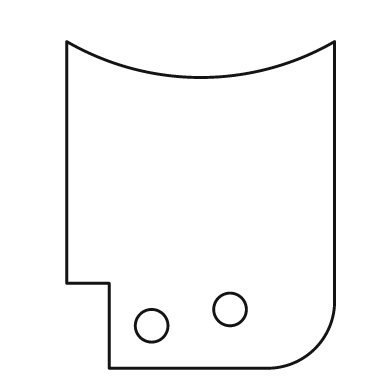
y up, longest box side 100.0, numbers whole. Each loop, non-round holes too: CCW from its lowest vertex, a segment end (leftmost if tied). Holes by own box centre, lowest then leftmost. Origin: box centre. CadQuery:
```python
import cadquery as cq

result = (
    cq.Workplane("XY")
    .moveTo(-28.0, -50.0)
    .lineTo(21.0, -50.0)
    .threePointArc((35.0, -44.0), (41.0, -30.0))
    .lineTo(41.0, 50.0)
    .threePointArc((0.0, 39.0), (-41.0, 50.0))
    .lineTo(-41.0, -24.0)
    .lineTo(-28.0, -24.0)
    .close()
    .moveTo(-15.0, -37.0)
    .circle(5.0)
    .moveTo(9.0, -32.0)
    .circle(5.0)
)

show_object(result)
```